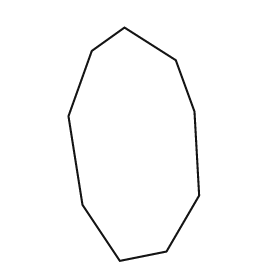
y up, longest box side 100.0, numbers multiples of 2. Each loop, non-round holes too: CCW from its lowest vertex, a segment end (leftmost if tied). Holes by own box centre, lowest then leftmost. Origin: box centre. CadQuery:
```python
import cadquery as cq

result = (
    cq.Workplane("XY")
    .moveTo(-6.0, -50.0)
    .lineTo(14.0, -46.0)
    .lineTo(28.0, -22.0)
    .lineTo(26.0, 14.0)
    .lineTo(18.0, 36.0)
    .lineTo(-4.0, 50.0)
    .lineTo(-18.0, 40.0)
    .lineTo(-28.0, 12.0)
    .lineTo(-22.0, -26.0)
    .close()
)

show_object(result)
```